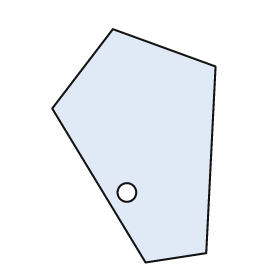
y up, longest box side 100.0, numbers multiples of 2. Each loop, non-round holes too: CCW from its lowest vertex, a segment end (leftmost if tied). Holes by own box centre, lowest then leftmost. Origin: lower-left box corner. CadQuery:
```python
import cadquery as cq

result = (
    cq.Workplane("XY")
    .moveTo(40.0, 0.0)
    .lineTo(66.0, 4.0)
    .lineTo(70.0, 84.0)
    .lineTo(26.0, 100.0)
    .lineTo(0.0, 66.0)
    .close()
    .moveTo(32.0, 30.0)
    .circle(4.0)
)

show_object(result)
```